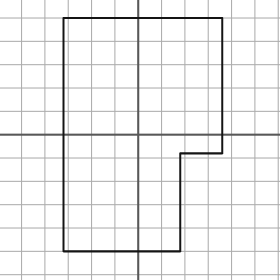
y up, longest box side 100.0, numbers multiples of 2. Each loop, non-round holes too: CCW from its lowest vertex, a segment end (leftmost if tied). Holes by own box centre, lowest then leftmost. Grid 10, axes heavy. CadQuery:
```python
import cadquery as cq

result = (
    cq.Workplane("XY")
    .moveTo(-32.0, -50.0)
    .lineTo(18.0, -50.0)
    .lineTo(18.0, -8.0)
    .lineTo(36.0, -8.0)
    .lineTo(36.0, 50.0)
    .lineTo(-32.0, 50.0)
    .close()
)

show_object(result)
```